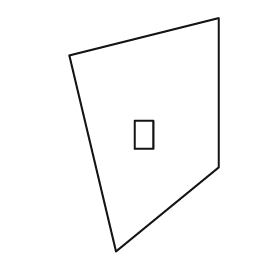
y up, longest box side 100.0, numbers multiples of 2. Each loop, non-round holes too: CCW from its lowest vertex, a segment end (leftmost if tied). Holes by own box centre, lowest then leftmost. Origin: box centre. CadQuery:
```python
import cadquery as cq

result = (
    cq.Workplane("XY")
    .moveTo(-12.0, -50.0)
    .lineTo(32.0, -14.0)
    .lineTo(32.0, 50.0)
    .lineTo(-32.0, 34.0)
    .close()
    .moveTo(-4.0, -6.0)
    .lineTo(4.0, -6.0)
    .lineTo(4.0, 6.0)
    .lineTo(-4.0, 6.0)
    .close()
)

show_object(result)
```